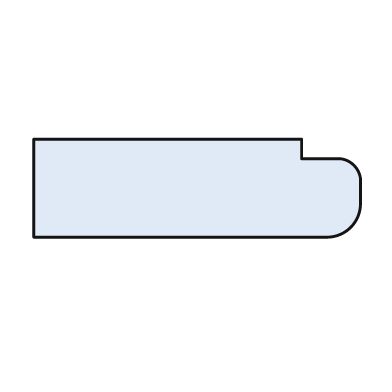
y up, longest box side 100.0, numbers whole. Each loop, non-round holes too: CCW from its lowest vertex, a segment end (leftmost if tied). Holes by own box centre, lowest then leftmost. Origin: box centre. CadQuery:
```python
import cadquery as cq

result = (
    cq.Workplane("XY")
    .moveTo(-50.0, -15.0)
    .lineTo(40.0, -15.0)
    .threePointArc((47.0, -12.0), (50.0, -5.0))
    .lineTo(50.0, 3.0)
    .threePointArc((48.0, 7.0), (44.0, 9.0))
    .lineTo(32.0, 9.0)
    .lineTo(32.0, 15.0)
    .lineTo(-50.0, 15.0)
    .close()
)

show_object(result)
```